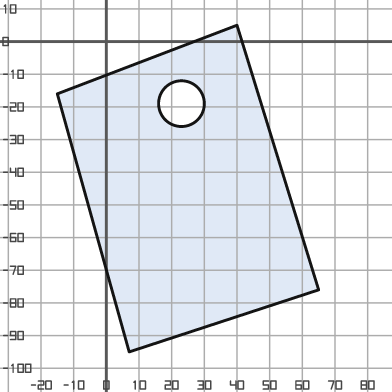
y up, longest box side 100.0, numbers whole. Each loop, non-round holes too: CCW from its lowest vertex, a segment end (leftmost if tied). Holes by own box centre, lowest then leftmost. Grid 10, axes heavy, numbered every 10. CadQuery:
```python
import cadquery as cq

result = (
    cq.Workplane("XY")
    .moveTo(7.0, -95.0)
    .lineTo(65.0, -76.0)
    .lineTo(40.0, 5.0)
    .lineTo(-15.0, -16.0)
    .close()
    .moveTo(23.0, -19.0)
    .circle(7.0)
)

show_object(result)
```